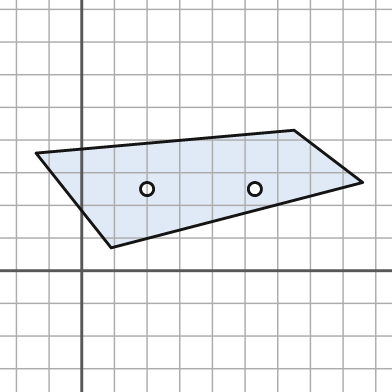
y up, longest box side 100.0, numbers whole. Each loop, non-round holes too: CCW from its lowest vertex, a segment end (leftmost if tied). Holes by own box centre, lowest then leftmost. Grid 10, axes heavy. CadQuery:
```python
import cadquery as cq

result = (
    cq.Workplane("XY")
    .moveTo(9.0, 7.0)
    .lineTo(86.0, 27.0)
    .lineTo(65.0, 43.0)
    .lineTo(-14.0, 36.0)
    .close()
    .moveTo(20.0, 25.0)
    .circle(2.0)
    .moveTo(53.0, 25.0)
    .circle(2.0)
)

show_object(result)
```